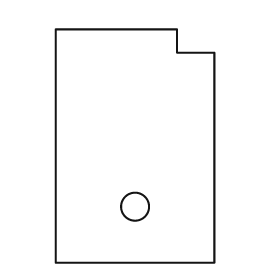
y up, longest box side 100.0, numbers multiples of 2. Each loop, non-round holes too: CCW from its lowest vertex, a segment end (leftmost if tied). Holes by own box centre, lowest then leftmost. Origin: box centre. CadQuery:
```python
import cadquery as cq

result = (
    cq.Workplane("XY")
    .moveTo(-34.0, -50.0)
    .lineTo(34.0, -50.0)
    .lineTo(34.0, 40.0)
    .lineTo(18.0, 40.0)
    .lineTo(18.0, 50.0)
    .lineTo(-34.0, 50.0)
    .close()
    .moveTo(0.0, -26.0)
    .circle(6.0)
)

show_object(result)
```